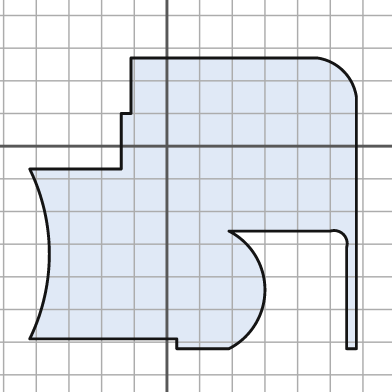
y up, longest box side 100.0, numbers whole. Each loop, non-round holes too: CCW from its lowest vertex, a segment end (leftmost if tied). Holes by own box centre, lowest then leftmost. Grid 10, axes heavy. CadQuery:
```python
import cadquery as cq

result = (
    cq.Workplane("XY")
    .moveTo(3.0, -62.0)
    .lineTo(19.0, -62.0)
    .threePointArc((30.0, -44.0), (19.0, -26.0))
    .lineTo(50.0, -26.0)
    .threePointArc((54.0, -27.0), (55.0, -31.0))
    .lineTo(55.0, -62.0)
    .lineTo(58.0, -62.0)
    .lineTo(58.0, 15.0)
    .threePointArc((54.0, 23.0), (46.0, 27.0))
    .lineTo(-11.0, 27.0)
    .lineTo(-11.0, 10.0)
    .lineTo(-14.0, 10.0)
    .lineTo(-14.0, -7.0)
    .lineTo(-42.0, -7.0)
    .threePointArc((-36.0, -33.0), (-42.0, -59.0))
    .lineTo(3.0, -59.0)
    .close()
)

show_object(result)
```